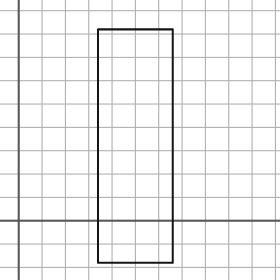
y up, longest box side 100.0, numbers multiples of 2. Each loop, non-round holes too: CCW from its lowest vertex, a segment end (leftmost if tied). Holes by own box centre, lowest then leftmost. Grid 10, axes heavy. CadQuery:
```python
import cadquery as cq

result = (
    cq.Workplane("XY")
    .moveTo(34.0, -18.0)
    .lineTo(66.0, -18.0)
    .lineTo(66.0, 82.0)
    .lineTo(34.0, 82.0)
    .close()
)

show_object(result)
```